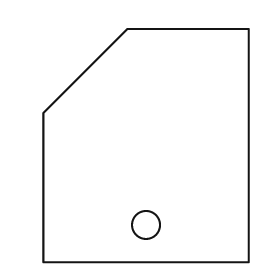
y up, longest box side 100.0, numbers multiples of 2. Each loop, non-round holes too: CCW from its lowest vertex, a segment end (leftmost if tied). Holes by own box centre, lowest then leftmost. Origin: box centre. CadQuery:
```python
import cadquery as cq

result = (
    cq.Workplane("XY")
    .moveTo(-44.0, -50.0)
    .lineTo(44.0, -50.0)
    .lineTo(44.0, 50.0)
    .lineTo(-8.0, 50.0)
    .lineTo(-44.0, 14.0)
    .close()
    .moveTo(0.0, -34.0)
    .circle(6.0)
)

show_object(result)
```